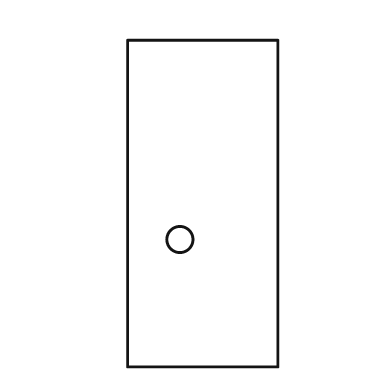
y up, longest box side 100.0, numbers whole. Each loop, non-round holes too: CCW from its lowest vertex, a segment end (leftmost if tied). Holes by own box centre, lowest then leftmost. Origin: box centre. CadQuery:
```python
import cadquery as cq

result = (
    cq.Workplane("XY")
    .moveTo(-23.0, -50.0)
    .lineTo(23.0, -50.0)
    .lineTo(23.0, 50.0)
    .lineTo(-23.0, 50.0)
    .close()
    .moveTo(-7.0, -11.0)
    .circle(4.0)
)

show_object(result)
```